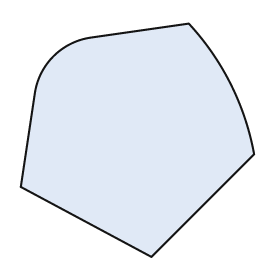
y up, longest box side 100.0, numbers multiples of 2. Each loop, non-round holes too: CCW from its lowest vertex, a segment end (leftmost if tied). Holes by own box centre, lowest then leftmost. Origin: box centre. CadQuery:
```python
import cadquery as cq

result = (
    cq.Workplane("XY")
    .moveTo(6.0, -50.0)
    .lineTo(50.0, -6.0)
    .threePointArc((40.0, 24.0), (22.0, 50.0))
    .lineTo(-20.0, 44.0)
    .threePointArc((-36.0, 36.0), (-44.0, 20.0))
    .lineTo(-50.0, -20.0)
    .close()
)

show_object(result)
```